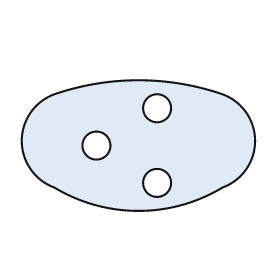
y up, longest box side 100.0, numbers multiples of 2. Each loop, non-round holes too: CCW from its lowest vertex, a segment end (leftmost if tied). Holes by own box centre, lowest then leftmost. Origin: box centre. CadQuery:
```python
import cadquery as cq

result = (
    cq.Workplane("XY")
    .moveTo(-36.0, -18.0)
    .threePointArc((0.0, -28.0), (36.0, -18.0))
    .threePointArc((50.0, 2.0), (36.0, 22.0))
    .threePointArc((0.0, 28.0), (-36.0, 22.0))
    .threePointArc((-50.0, 2.0), (-36.0, -18.0))
    .close()
    .moveTo(8.0, -16.0)
    .circle(6.0)
    .moveTo(-18.0, 0.0)
    .circle(6.0)
    .moveTo(8.0, 16.0)
    .circle(6.0)
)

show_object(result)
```